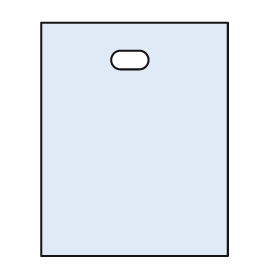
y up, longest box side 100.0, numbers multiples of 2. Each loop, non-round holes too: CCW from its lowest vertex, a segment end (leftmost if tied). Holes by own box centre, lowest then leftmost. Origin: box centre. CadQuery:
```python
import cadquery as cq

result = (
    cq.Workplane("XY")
    .moveTo(-40.0, -50.0)
    .lineTo(40.0, -50.0)
    .lineTo(40.0, 50.0)
    .lineTo(-40.0, 50.0)
    .close()
    .moveTo(-6.0, 30.0)
    .lineTo(2.0, 30.0)
    .threePointArc((6.0, 34.0), (2.0, 38.0))
    .lineTo(-6.0, 38.0)
    .threePointArc((-10.0, 34.0), (-6.0, 30.0))
    .close()
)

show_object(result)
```